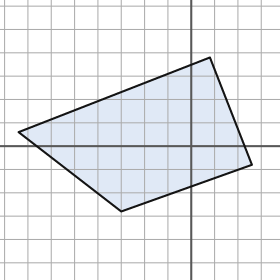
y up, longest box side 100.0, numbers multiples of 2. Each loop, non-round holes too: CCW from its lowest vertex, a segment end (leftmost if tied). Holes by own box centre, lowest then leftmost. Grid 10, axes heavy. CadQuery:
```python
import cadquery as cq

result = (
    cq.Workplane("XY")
    .moveTo(-30.0, -28.0)
    .lineTo(26.0, -8.0)
    .lineTo(8.0, 38.0)
    .lineTo(-74.0, 6.0)
    .close()
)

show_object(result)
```